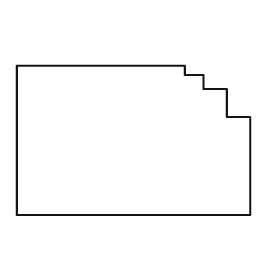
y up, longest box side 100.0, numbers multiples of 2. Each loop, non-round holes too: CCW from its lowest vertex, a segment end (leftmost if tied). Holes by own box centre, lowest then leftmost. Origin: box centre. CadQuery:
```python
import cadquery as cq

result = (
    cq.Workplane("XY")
    .moveTo(-50.0, -32.0)
    .lineTo(50.0, -32.0)
    .lineTo(50.0, 10.0)
    .lineTo(40.0, 10.0)
    .lineTo(40.0, 22.0)
    .lineTo(30.0, 22.0)
    .lineTo(30.0, 28.0)
    .lineTo(22.0, 28.0)
    .lineTo(22.0, 32.0)
    .lineTo(-50.0, 32.0)
    .close()
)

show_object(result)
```